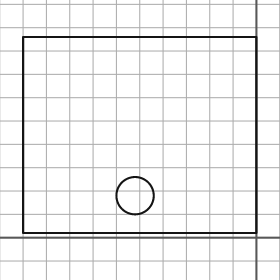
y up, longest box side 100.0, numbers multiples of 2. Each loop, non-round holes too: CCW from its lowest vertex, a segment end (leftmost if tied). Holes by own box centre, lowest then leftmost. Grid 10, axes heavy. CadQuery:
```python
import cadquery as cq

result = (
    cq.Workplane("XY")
    .moveTo(-100.0, 2.0)
    .lineTo(0.0, 2.0)
    .lineTo(0.0, 86.0)
    .lineTo(-100.0, 86.0)
    .close()
    .moveTo(-52.0, 18.0)
    .circle(8.0)
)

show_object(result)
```